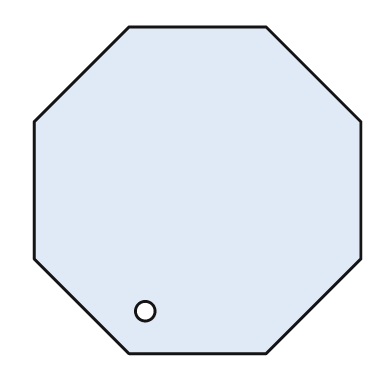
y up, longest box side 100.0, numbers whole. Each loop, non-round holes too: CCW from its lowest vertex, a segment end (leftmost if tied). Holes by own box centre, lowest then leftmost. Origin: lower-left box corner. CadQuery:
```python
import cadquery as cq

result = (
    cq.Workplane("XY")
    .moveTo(29.0, 0.0)
    .lineTo(71.0, 0.0)
    .lineTo(100.0, 29.0)
    .lineTo(100.0, 71.0)
    .lineTo(71.0, 100.0)
    .lineTo(29.0, 100.0)
    .lineTo(0.0, 71.0)
    .lineTo(0.0, 29.0)
    .close()
    .moveTo(34.0, 13.0)
    .circle(3.0)
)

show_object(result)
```